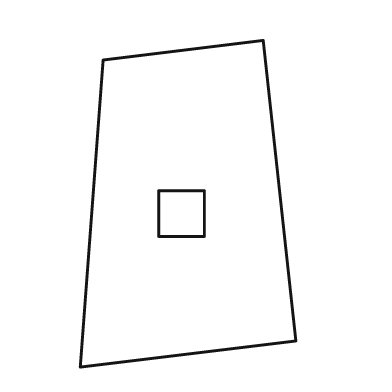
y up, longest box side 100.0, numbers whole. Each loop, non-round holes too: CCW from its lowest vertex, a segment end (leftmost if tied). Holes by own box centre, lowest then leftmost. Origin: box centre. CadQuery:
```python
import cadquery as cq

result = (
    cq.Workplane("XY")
    .moveTo(-33.0, -50.0)
    .lineTo(33.0, -42.0)
    .lineTo(23.0, 50.0)
    .lineTo(-26.0, 44.0)
    .close()
    .moveTo(-9.0, -10.0)
    .lineTo(5.0, -10.0)
    .lineTo(5.0, 4.0)
    .lineTo(-9.0, 4.0)
    .close()
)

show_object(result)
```